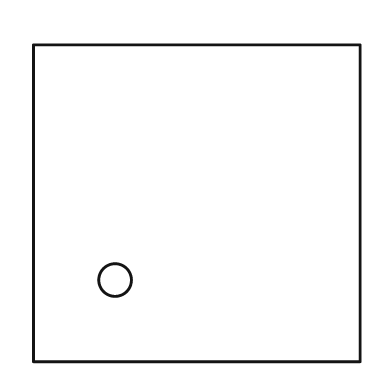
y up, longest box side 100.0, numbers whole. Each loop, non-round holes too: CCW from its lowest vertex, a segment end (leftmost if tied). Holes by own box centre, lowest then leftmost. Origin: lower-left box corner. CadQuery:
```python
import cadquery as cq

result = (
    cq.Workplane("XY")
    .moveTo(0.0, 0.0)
    .lineTo(100.0, 0.0)
    .lineTo(100.0, 97.0)
    .lineTo(0.0, 97.0)
    .close()
    .moveTo(25.0, 25.0)
    .circle(5.0)
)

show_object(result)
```